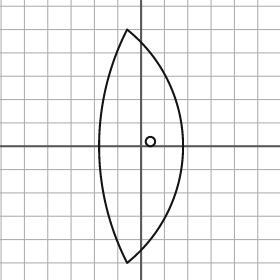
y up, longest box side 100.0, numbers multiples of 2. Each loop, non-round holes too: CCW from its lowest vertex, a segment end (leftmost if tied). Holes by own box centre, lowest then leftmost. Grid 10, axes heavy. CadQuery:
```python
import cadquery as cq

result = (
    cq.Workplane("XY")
    .moveTo(-6.0, -50.0)
    .threePointArc((18.0, 0.0), (-6.0, 50.0))
    .threePointArc((-18.0, 0.0), (-6.0, -50.0))
    .close()
    .moveTo(4.0, 2.0)
    .circle(2.0)
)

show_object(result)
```